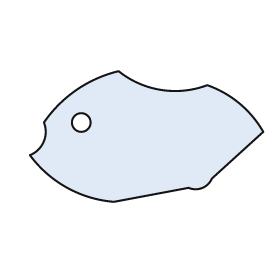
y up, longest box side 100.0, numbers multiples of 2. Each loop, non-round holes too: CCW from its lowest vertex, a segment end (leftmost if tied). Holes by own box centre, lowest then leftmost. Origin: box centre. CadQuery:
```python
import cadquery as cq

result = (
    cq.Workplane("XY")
    .moveTo(-14.0, -28.0)
    .lineTo(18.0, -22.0)
    .threePointArc((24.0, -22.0), (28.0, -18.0))
    .lineTo(50.0, 2.0)
    .threePointArc((40.0, 14.0), (26.0, 22.0))
    .threePointArc((6.0, 20.0), (-12.0, 28.0))
    .threePointArc((-30.0, 20.0), (-44.0, 6.0))
    .threePointArc((-44.0, -2.0), (-50.0, -8.0))
    .threePointArc((-34.0, -22.0), (-14.0, -28.0))
    .close()
    .moveTo(-28.0, 6.0)
    .circle(4.0)
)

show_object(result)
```